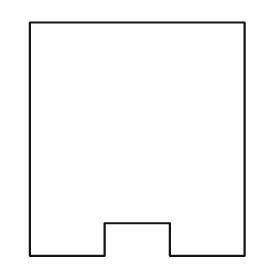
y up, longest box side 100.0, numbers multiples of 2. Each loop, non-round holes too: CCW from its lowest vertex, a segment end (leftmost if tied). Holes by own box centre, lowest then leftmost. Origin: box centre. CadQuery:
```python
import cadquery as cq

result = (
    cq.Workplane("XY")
    .moveTo(-46.0, -50.0)
    .lineTo(-14.0, -50.0)
    .lineTo(-14.0, -36.0)
    .lineTo(14.0, -36.0)
    .lineTo(14.0, -50.0)
    .lineTo(46.0, -50.0)
    .lineTo(46.0, 50.0)
    .lineTo(-46.0, 50.0)
    .close()
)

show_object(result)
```